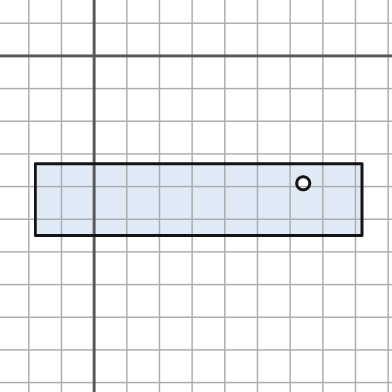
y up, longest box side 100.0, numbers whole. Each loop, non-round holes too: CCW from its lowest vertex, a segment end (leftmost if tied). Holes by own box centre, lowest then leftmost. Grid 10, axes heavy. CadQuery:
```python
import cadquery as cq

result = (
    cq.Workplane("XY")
    .moveTo(-18.0, -55.0)
    .lineTo(82.0, -55.0)
    .lineTo(82.0, -33.0)
    .lineTo(-18.0, -33.0)
    .close()
    .moveTo(64.0, -39.0)
    .circle(2.0)
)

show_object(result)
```